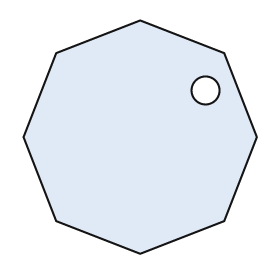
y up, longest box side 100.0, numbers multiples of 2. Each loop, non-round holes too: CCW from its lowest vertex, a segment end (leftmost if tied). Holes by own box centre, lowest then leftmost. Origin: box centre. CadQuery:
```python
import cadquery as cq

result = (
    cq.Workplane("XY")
    .moveTo(0.0, -50.0)
    .lineTo(36.0, -36.0)
    .lineTo(50.0, 0.0)
    .lineTo(36.0, 36.0)
    .lineTo(0.0, 50.0)
    .lineTo(-36.0, 36.0)
    .lineTo(-50.0, 0.0)
    .lineTo(-36.0, -36.0)
    .close()
    .moveTo(28.0, 20.0)
    .circle(6.0)
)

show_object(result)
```